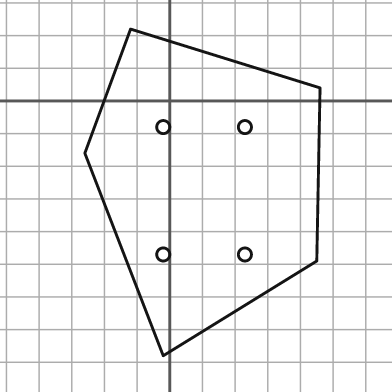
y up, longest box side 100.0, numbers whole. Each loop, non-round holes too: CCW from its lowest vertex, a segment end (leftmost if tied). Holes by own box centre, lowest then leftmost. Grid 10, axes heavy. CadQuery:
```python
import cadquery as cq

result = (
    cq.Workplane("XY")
    .moveTo(-2.0, -78.0)
    .lineTo(45.0, -49.0)
    .lineTo(46.0, 4.0)
    .lineTo(-12.0, 22.0)
    .lineTo(-26.0, -16.0)
    .close()
    .moveTo(-2.0, -47.0)
    .circle(2.0)
    .moveTo(23.0, -47.0)
    .circle(2.0)
    .moveTo(-2.0, -8.0)
    .circle(2.0)
    .moveTo(23.0, -8.0)
    .circle(2.0)
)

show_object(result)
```